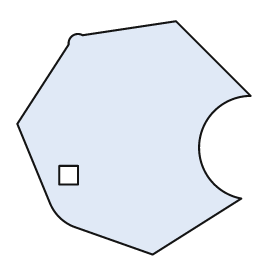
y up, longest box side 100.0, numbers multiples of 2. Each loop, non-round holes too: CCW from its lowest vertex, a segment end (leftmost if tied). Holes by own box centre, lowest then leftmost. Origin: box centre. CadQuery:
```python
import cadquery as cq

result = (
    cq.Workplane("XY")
    .moveTo(8.0, -50.0)
    .lineTo(46.0, -26.0)
    .threePointArc((28.0, -2.0), (50.0, 18.0))
    .lineTo(18.0, 50.0)
    .lineTo(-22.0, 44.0)
    .threePointArc((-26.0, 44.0), (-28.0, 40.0))
    .lineTo(-50.0, 6.0)
    .lineTo(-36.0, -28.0)
    .threePointArc((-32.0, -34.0), (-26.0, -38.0))
    .close()
    .moveTo(-32.0, -20.0)
    .lineTo(-24.0, -20.0)
    .lineTo(-24.0, -12.0)
    .lineTo(-32.0, -12.0)
    .close()
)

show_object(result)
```